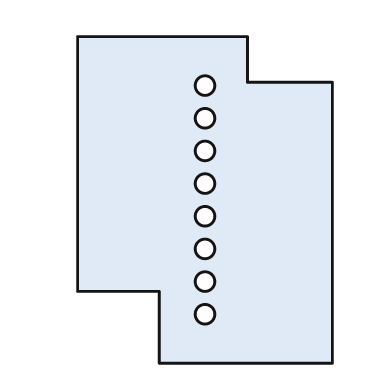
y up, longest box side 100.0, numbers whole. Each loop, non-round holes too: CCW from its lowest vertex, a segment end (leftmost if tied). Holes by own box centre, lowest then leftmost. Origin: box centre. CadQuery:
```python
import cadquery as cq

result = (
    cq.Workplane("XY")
    .moveTo(-14.0, -50.0)
    .lineTo(39.0, -50.0)
    .lineTo(39.0, 36.0)
    .lineTo(13.0, 36.0)
    .lineTo(13.0, 50.0)
    .lineTo(-39.0, 50.0)
    .lineTo(-39.0, -28.0)
    .lineTo(-14.0, -28.0)
    .close()
    .moveTo(0.0, -35.0)
    .circle(3.0)
    .moveTo(0.0, -25.0)
    .circle(3.0)
    .moveTo(0.0, -15.0)
    .circle(3.0)
    .moveTo(0.0, -5.0)
    .circle(3.0)
    .moveTo(0.0, 5.0)
    .circle(3.0)
    .moveTo(0.0, 15.0)
    .circle(3.0)
    .moveTo(0.0, 25.0)
    .circle(3.0)
    .moveTo(0.0, 35.0)
    .circle(3.0)
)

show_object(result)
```